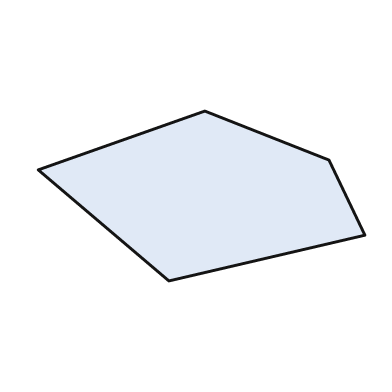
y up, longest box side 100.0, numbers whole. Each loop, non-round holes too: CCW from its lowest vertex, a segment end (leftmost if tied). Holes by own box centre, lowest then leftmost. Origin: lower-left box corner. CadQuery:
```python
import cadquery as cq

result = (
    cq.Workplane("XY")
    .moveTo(40.0, 0.0)
    .lineTo(100.0, 14.0)
    .lineTo(89.0, 37.0)
    .lineTo(51.0, 52.0)
    .lineTo(0.0, 34.0)
    .close()
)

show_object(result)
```